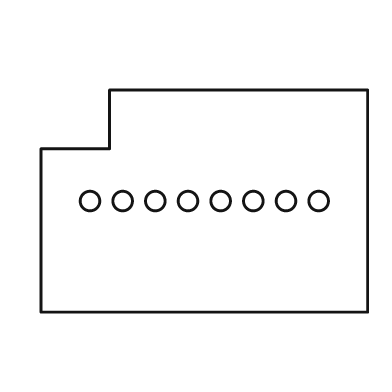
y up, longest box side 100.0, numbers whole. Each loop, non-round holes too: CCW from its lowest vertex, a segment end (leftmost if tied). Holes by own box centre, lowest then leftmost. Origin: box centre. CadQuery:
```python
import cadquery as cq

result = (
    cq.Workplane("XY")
    .moveTo(-50.0, -34.0)
    .lineTo(50.0, -34.0)
    .lineTo(50.0, 34.0)
    .lineTo(-29.0, 34.0)
    .lineTo(-29.0, 16.0)
    .lineTo(-50.0, 16.0)
    .close()
    .moveTo(-35.0, 0.0)
    .circle(3.0)
    .moveTo(-25.0, 0.0)
    .circle(3.0)
    .moveTo(-15.0, 0.0)
    .circle(3.0)
    .moveTo(-5.0, 0.0)
    .circle(3.0)
    .moveTo(5.0, 0.0)
    .circle(3.0)
    .moveTo(15.0, 0.0)
    .circle(3.0)
    .moveTo(25.0, 0.0)
    .circle(3.0)
    .moveTo(35.0, 0.0)
    .circle(3.0)
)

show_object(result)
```